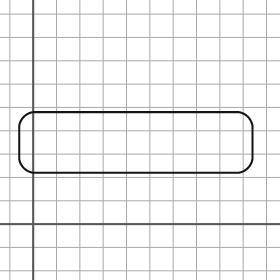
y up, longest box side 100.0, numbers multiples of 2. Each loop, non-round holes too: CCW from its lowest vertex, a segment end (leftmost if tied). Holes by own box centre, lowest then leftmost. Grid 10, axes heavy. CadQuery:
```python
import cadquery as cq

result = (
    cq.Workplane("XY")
    .moveTo(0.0, 22.0)
    .lineTo(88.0, 22.0)
    .threePointArc((92.0, 24.0), (94.0, 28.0))
    .lineTo(94.0, 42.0)
    .threePointArc((92.0, 46.0), (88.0, 48.0))
    .lineTo(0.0, 48.0)
    .threePointArc((-4.0, 46.0), (-6.0, 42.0))
    .lineTo(-6.0, 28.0)
    .threePointArc((-4.0, 24.0), (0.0, 22.0))
    .close()
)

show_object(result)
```